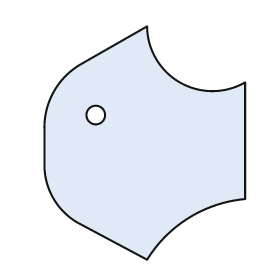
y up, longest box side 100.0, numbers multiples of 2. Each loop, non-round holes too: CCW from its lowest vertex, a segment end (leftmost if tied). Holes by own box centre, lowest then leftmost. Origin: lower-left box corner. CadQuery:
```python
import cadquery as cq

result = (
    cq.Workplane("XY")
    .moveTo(44.0, 0.0)
    .threePointArc((62.0, 18.0), (86.0, 26.0))
    .lineTo(86.0, 76.0)
    .threePointArc((58.0, 76.0), (44.0, 100.0))
    .lineTo(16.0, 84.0)
    .threePointArc((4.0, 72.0), (0.0, 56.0))
    .lineTo(0.0, 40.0)
    .threePointArc((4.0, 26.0), (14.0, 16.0))
    .close()
    .moveTo(22.0, 62.0)
    .circle(4.0)
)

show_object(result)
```